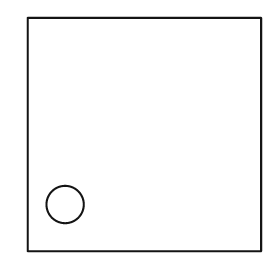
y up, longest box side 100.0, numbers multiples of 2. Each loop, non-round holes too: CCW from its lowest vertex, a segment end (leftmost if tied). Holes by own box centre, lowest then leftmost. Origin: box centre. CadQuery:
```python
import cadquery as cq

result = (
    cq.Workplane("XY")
    .moveTo(-50.0, -50.0)
    .lineTo(50.0, -50.0)
    .lineTo(50.0, 50.0)
    .lineTo(-50.0, 50.0)
    .close()
    .moveTo(-34.0, -30.0)
    .circle(8.0)
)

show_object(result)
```